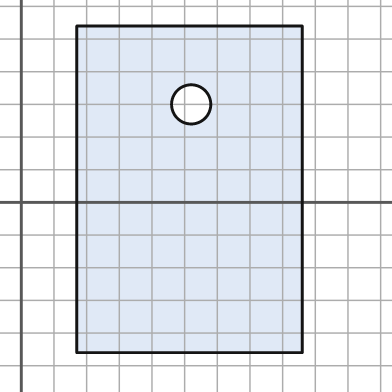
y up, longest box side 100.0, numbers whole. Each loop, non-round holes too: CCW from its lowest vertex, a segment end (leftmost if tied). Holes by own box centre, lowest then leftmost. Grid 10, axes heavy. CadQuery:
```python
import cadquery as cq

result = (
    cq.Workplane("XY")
    .moveTo(17.0, -46.0)
    .lineTo(86.0, -46.0)
    .lineTo(86.0, 54.0)
    .lineTo(17.0, 54.0)
    .close()
    .moveTo(52.0, 30.0)
    .circle(6.0)
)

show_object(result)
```